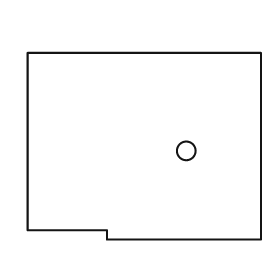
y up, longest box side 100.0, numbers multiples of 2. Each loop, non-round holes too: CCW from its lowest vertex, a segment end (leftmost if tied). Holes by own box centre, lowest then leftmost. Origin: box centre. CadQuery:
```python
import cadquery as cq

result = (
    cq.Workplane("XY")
    .moveTo(-16.0, -40.0)
    .lineTo(50.0, -40.0)
    .lineTo(50.0, 40.0)
    .lineTo(-50.0, 40.0)
    .lineTo(-50.0, -36.0)
    .lineTo(-16.0, -36.0)
    .close()
    .moveTo(18.0, -2.0)
    .circle(4.0)
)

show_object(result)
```